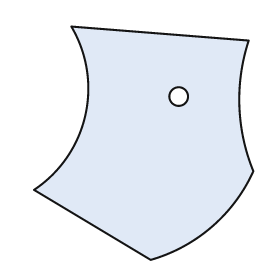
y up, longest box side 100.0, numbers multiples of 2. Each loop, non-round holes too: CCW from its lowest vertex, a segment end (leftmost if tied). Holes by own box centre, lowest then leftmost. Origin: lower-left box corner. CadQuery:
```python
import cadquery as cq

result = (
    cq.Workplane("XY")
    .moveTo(50.0, 0.0)
    .threePointArc((76.0, 14.0), (94.0, 38.0))
    .threePointArc((88.0, 66.0), (92.0, 94.0))
    .lineTo(16.0, 100.0)
    .threePointArc((22.0, 62.0), (0.0, 30.0))
    .close()
    .moveTo(62.0, 70.0)
    .circle(4.0)
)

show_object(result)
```